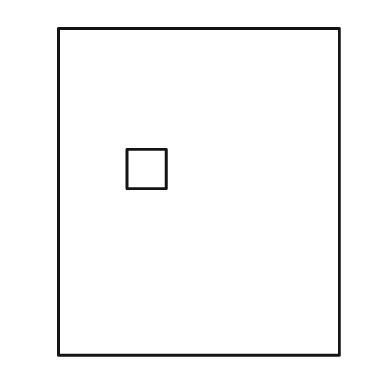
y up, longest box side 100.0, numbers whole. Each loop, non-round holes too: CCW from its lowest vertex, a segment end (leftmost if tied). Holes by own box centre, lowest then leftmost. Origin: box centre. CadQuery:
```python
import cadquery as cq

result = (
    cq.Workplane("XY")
    .moveTo(-43.0, -50.0)
    .lineTo(43.0, -50.0)
    .lineTo(43.0, 50.0)
    .lineTo(-43.0, 50.0)
    .close()
    .moveTo(-22.0, 1.0)
    .lineTo(-10.0, 1.0)
    .lineTo(-10.0, 13.0)
    .lineTo(-22.0, 13.0)
    .close()
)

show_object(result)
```